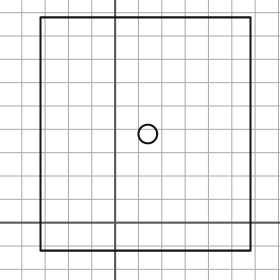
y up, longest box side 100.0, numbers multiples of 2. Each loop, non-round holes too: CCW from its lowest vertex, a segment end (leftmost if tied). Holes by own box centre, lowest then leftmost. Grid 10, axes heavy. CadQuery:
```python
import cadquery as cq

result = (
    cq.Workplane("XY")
    .moveTo(-32.0, -12.0)
    .lineTo(58.0, -12.0)
    .lineTo(58.0, 88.0)
    .lineTo(-32.0, 88.0)
    .close()
    .moveTo(14.0, 38.0)
    .circle(4.0)
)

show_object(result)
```